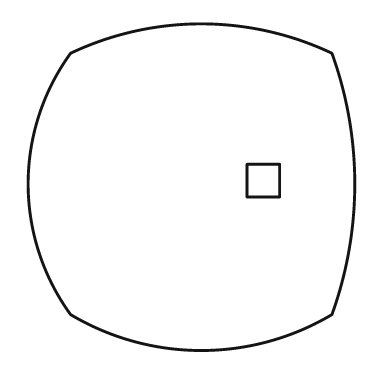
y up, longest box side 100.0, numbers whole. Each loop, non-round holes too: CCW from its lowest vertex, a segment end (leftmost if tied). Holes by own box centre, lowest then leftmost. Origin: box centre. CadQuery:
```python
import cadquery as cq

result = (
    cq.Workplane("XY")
    .moveTo(-37.0, -39.0)
    .threePointArc((3.0, -50.0), (43.0, -39.0))
    .threePointArc((50.0, 1.0), (43.0, 41.0))
    .threePointArc((3.0, 50.0), (-37.0, 41.0))
    .threePointArc((-50.0, 1.0), (-37.0, -39.0))
    .close()
    .moveTo(17.0, -3.0)
    .lineTo(27.0, -3.0)
    .lineTo(27.0, 7.0)
    .lineTo(17.0, 7.0)
    .close()
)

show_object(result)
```